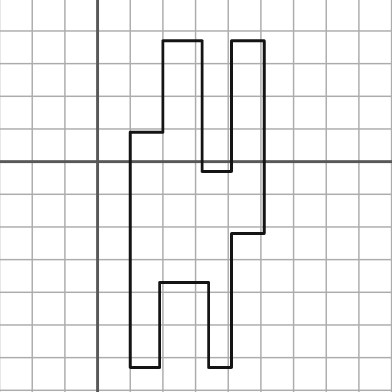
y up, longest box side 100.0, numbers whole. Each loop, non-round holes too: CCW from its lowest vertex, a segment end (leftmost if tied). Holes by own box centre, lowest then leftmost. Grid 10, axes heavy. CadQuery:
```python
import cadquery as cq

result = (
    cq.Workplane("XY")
    .moveTo(10.0, -63.0)
    .lineTo(19.0, -63.0)
    .lineTo(19.0, -37.0)
    .lineTo(34.0, -37.0)
    .lineTo(34.0, -63.0)
    .lineTo(41.0, -63.0)
    .lineTo(41.0, -22.0)
    .lineTo(51.0, -22.0)
    .lineTo(51.0, 37.0)
    .lineTo(41.0, 37.0)
    .lineTo(41.0, -3.0)
    .lineTo(32.0, -3.0)
    .lineTo(32.0, 37.0)
    .lineTo(20.0, 37.0)
    .lineTo(20.0, 9.0)
    .lineTo(10.0, 9.0)
    .close()
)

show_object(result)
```